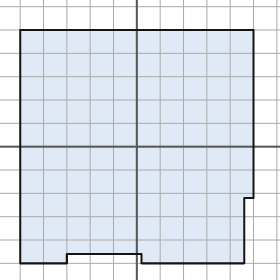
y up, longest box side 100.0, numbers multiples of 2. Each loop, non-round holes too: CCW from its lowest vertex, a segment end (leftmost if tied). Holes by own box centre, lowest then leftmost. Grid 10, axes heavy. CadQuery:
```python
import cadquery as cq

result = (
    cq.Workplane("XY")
    .moveTo(-50.0, -50.0)
    .lineTo(-30.0, -50.0)
    .lineTo(-30.0, -46.0)
    .lineTo(2.0, -46.0)
    .lineTo(2.0, -50.0)
    .lineTo(46.0, -50.0)
    .lineTo(46.0, -22.0)
    .lineTo(50.0, -22.0)
    .lineTo(50.0, 50.0)
    .lineTo(-50.0, 50.0)
    .close()
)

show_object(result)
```